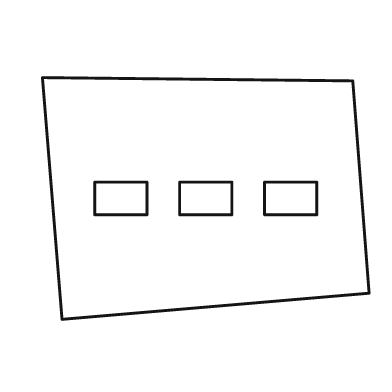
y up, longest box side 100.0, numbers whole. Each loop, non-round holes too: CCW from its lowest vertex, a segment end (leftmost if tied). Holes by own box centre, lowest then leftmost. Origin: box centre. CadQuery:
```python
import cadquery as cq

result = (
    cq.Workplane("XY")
    .moveTo(-44.0, -37.0)
    .lineTo(50.0, -29.0)
    .lineTo(45.0, 36.0)
    .lineTo(-50.0, 37.0)
    .close()
    .moveTo(-34.0, -5.0)
    .lineTo(-18.0, -5.0)
    .lineTo(-18.0, 5.0)
    .lineTo(-34.0, 5.0)
    .close()
    .moveTo(-8.0, -5.0)
    .lineTo(8.0, -5.0)
    .lineTo(8.0, 5.0)
    .lineTo(-8.0, 5.0)
    .close()
    .moveTo(18.0, -5.0)
    .lineTo(34.0, -5.0)
    .lineTo(34.0, 5.0)
    .lineTo(18.0, 5.0)
    .close()
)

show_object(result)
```